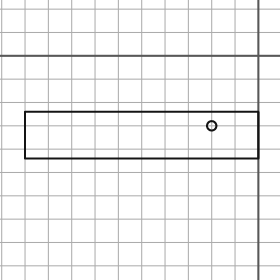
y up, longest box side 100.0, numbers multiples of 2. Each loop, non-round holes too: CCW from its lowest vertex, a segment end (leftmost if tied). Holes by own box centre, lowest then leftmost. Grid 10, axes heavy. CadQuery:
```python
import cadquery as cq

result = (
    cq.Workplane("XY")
    .moveTo(-100.0, -44.0)
    .lineTo(0.0, -44.0)
    .lineTo(0.0, -24.0)
    .lineTo(-100.0, -24.0)
    .close()
    .moveTo(-20.0, -30.0)
    .circle(2.0)
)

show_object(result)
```